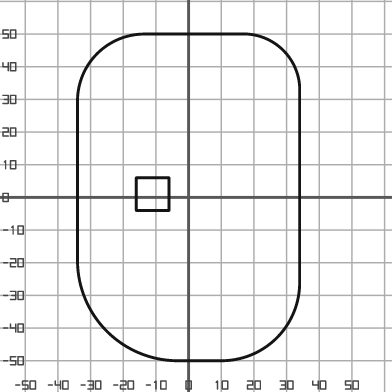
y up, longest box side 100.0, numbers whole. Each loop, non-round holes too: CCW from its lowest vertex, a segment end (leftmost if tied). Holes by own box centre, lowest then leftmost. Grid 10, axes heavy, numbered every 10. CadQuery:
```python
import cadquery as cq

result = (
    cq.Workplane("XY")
    .moveTo(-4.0, -50.0)
    .lineTo(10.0, -50.0)
    .threePointArc((27.0, -43.0), (34.0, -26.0))
    .lineTo(34.0, 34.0)
    .threePointArc((29.0, 45.0), (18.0, 50.0))
    .lineTo(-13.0, 50.0)
    .threePointArc((-28.0, 44.0), (-34.0, 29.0))
    .lineTo(-34.0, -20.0)
    .threePointArc((-25.0, -41.0), (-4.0, -50.0))
    .close()
    .moveTo(-16.0, -4.0)
    .lineTo(-6.0, -4.0)
    .lineTo(-6.0, 6.0)
    .lineTo(-16.0, 6.0)
    .close()
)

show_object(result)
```